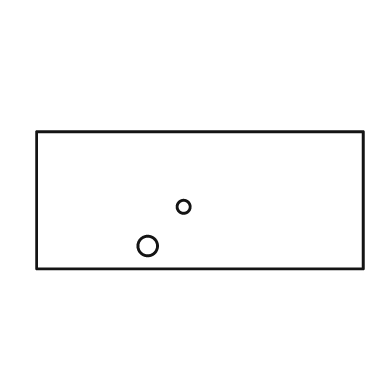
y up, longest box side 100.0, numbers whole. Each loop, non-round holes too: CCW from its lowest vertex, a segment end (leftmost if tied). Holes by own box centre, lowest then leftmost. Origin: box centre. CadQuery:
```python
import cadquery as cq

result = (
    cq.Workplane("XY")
    .moveTo(-50.0, -21.0)
    .lineTo(50.0, -21.0)
    .lineTo(50.0, 21.0)
    .lineTo(-50.0, 21.0)
    .close()
    .moveTo(-16.0, -14.0)
    .circle(3.0)
    .moveTo(-5.0, -2.0)
    .circle(2.0)
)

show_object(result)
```